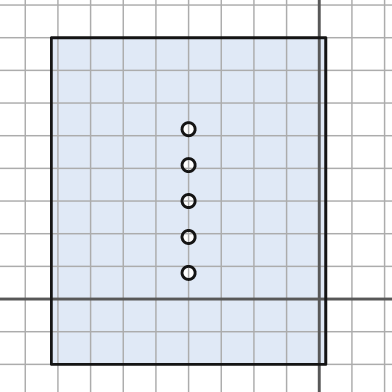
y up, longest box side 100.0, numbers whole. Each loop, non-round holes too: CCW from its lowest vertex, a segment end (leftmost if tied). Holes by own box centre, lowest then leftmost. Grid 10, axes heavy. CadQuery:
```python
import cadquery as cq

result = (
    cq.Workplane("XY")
    .moveTo(-82.0, -20.0)
    .lineTo(2.0, -20.0)
    .lineTo(2.0, 80.0)
    .lineTo(-82.0, 80.0)
    .close()
    .moveTo(-40.0, 8.0)
    .circle(2.0)
    .moveTo(-40.0, 19.0)
    .circle(2.0)
    .moveTo(-40.0, 30.0)
    .circle(2.0)
    .moveTo(-40.0, 41.0)
    .circle(2.0)
    .moveTo(-40.0, 52.0)
    .circle(2.0)
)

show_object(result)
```